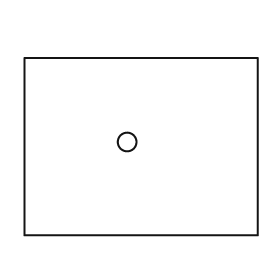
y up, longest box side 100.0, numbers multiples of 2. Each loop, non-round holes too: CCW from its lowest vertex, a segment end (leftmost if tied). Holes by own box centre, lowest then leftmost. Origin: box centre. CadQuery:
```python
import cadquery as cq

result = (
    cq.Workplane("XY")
    .moveTo(-50.0, -38.0)
    .lineTo(50.0, -38.0)
    .lineTo(50.0, 38.0)
    .lineTo(-50.0, 38.0)
    .close()
    .moveTo(-6.0, 2.0)
    .circle(4.0)
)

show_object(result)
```